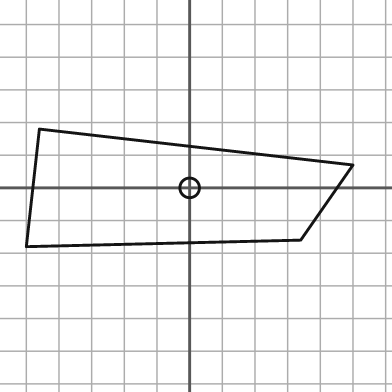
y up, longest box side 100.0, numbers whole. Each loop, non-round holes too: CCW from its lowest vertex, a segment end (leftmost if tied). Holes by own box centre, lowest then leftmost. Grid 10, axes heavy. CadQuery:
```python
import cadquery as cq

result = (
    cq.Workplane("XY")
    .moveTo(-50.0, -18.0)
    .lineTo(34.0, -16.0)
    .lineTo(50.0, 7.0)
    .lineTo(-46.0, 18.0)
    .close()
    .moveTo(0.0, 0.0)
    .circle(3.0)
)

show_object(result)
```